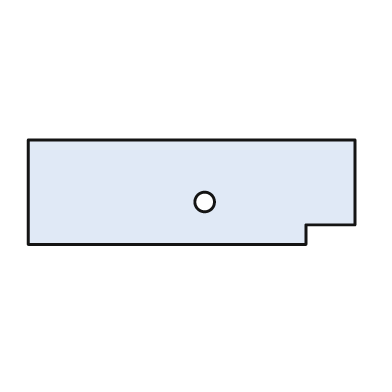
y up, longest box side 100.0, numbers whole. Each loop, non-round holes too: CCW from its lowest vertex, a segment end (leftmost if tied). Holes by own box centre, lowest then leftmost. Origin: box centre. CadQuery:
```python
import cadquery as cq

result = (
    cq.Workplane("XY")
    .moveTo(-50.0, -16.0)
    .lineTo(35.0, -16.0)
    .lineTo(35.0, -10.0)
    .lineTo(50.0, -10.0)
    .lineTo(50.0, 16.0)
    .lineTo(-50.0, 16.0)
    .close()
    .moveTo(4.0, -3.0)
    .circle(3.0)
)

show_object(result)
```